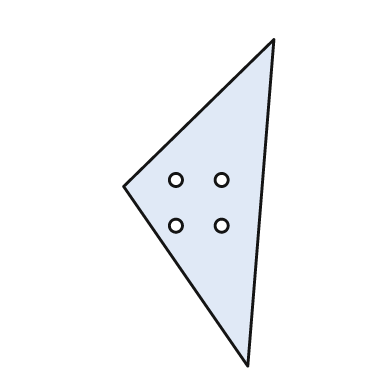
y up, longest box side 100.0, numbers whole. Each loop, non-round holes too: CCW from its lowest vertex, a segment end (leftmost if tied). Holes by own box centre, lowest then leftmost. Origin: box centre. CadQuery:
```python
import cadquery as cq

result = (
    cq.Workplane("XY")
    .moveTo(15.0, -50.0)
    .lineTo(23.0, 50.0)
    .lineTo(-23.0, 5.0)
    .close()
    .moveTo(-7.0, -7.0)
    .circle(2.0)
    .moveTo(7.0, -7.0)
    .circle(2.0)
    .moveTo(-7.0, 7.0)
    .circle(2.0)
    .moveTo(7.0, 7.0)
    .circle(2.0)
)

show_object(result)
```